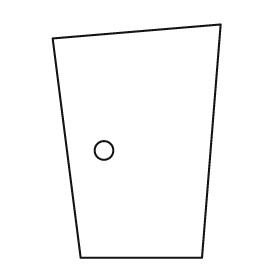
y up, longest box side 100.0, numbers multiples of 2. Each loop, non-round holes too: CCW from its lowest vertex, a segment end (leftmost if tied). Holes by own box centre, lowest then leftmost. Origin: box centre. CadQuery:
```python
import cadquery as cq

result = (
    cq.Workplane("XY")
    .moveTo(-24.0, -50.0)
    .lineTo(28.0, -50.0)
    .lineTo(36.0, 50.0)
    .lineTo(-36.0, 44.0)
    .close()
    .moveTo(-14.0, -4.0)
    .circle(4.0)
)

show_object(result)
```